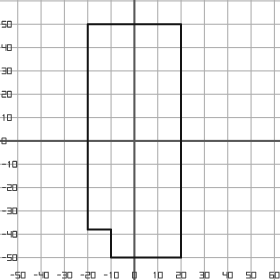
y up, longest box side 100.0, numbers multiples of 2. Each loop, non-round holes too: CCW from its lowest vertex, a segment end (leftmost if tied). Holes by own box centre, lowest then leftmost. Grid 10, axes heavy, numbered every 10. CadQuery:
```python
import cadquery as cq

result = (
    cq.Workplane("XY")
    .moveTo(-10.0, -50.0)
    .lineTo(20.0, -50.0)
    .lineTo(20.0, 50.0)
    .lineTo(-20.0, 50.0)
    .lineTo(-20.0, -38.0)
    .lineTo(-10.0, -38.0)
    .close()
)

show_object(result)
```